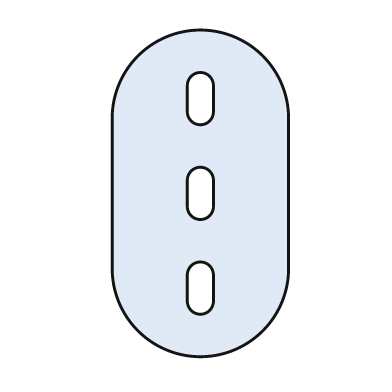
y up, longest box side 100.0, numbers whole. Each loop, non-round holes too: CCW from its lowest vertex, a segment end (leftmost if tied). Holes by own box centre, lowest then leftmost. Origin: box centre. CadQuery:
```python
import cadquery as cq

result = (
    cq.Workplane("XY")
    .moveTo(-27.0, -23.0)
    .threePointArc((0.0, -50.0), (27.0, -23.0))
    .lineTo(27.0, 23.0)
    .threePointArc((0.0, 50.0), (-27.0, 23.0))
    .close()
    .moveTo(-4.0, -33.0)
    .threePointArc((0.0, -37.0), (4.0, -33.0))
    .lineTo(4.0, -25.0)
    .threePointArc((0.0, -21.0), (-4.0, -25.0))
    .close()
    .moveTo(-4.0, -4.0)
    .threePointArc((0.0, -8.0), (4.0, -4.0))
    .lineTo(4.0, 4.0)
    .threePointArc((0.0, 8.0), (-4.0, 4.0))
    .close()
    .moveTo(-4.0, 25.0)
    .threePointArc((0.0, 21.0), (4.0, 25.0))
    .lineTo(4.0, 33.0)
    .threePointArc((0.0, 37.0), (-4.0, 33.0))
    .close()
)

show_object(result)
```